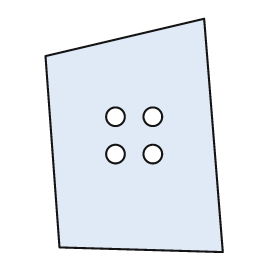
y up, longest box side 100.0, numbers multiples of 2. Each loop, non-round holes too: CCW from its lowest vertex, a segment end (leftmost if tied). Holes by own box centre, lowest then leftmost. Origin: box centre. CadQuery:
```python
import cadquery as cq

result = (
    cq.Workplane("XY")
    .moveTo(38.0, -50.0)
    .lineTo(30.0, 50.0)
    .lineTo(-38.0, 34.0)
    .lineTo(-32.0, -48.0)
    .close()
    .moveTo(-8.0, -8.0)
    .circle(4.0)
    .moveTo(8.0, -8.0)
    .circle(4.0)
    .moveTo(-8.0, 8.0)
    .circle(4.0)
    .moveTo(8.0, 8.0)
    .circle(4.0)
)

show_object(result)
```